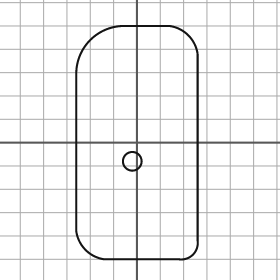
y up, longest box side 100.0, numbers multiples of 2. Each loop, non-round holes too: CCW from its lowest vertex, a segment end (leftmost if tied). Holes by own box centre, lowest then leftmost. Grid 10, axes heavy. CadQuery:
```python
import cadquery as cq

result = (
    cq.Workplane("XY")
    .moveTo(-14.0, -50.0)
    .lineTo(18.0, -50.0)
    .threePointArc((24.0, -48.0), (26.0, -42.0))
    .lineTo(26.0, 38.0)
    .threePointArc((22.0, 46.0), (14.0, 50.0))
    .lineTo(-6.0, 50.0)
    .threePointArc((-20.0, 44.0), (-26.0, 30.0))
    .lineTo(-26.0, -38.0)
    .threePointArc((-22.0, -46.0), (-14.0, -50.0))
    .close()
    .moveTo(-2.0, -8.0)
    .circle(4.0)
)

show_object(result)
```